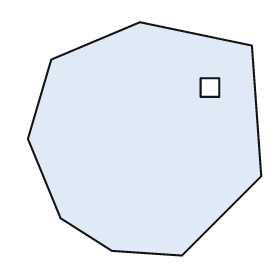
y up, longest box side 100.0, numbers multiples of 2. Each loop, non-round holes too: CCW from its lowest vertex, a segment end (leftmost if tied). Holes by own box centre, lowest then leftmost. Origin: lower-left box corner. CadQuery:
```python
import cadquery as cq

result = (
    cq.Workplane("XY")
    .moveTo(66.0, 0.0)
    .lineTo(100.0, 34.0)
    .lineTo(96.0, 90.0)
    .lineTo(48.0, 100.0)
    .lineTo(10.0, 84.0)
    .lineTo(0.0, 50.0)
    .lineTo(14.0, 16.0)
    .lineTo(36.0, 2.0)
    .close()
    .moveTo(74.0, 68.0)
    .lineTo(82.0, 68.0)
    .lineTo(82.0, 76.0)
    .lineTo(74.0, 76.0)
    .close()
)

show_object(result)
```